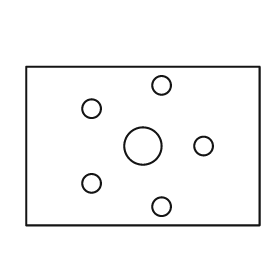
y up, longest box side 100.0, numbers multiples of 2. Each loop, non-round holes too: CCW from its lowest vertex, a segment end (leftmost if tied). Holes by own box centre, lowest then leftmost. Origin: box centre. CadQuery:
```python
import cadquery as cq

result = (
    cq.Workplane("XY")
    .moveTo(-50.0, -34.0)
    .lineTo(50.0, -34.0)
    .lineTo(50.0, 34.0)
    .lineTo(-50.0, 34.0)
    .close()
    .moveTo(8.0, -26.0)
    .circle(4.0)
    .moveTo(-22.0, -16.0)
    .circle(4.0)
    .moveTo(0.0, 0.0)
    .circle(8.0)
    .moveTo(26.0, 0.0)
    .circle(4.0)
    .moveTo(-22.0, 16.0)
    .circle(4.0)
    .moveTo(8.0, 26.0)
    .circle(4.0)
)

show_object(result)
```